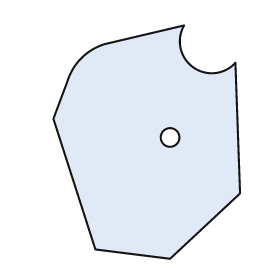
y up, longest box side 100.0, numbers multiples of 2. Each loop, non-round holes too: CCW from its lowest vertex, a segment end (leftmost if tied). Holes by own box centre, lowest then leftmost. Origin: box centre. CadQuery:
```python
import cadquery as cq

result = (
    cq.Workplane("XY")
    .moveTo(10.0, -50.0)
    .lineTo(40.0, -22.0)
    .lineTo(38.0, 34.0)
    .threePointArc((20.0, 32.0), (16.0, 50.0))
    .lineTo(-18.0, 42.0)
    .threePointArc((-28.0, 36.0), (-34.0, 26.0))
    .lineTo(-40.0, 10.0)
    .lineTo(-22.0, -46.0)
    .close()
    .moveTo(10.0, 2.0)
    .circle(4.0)
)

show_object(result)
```